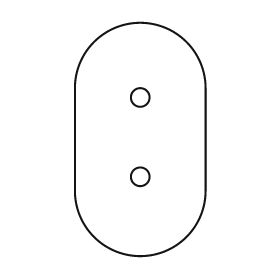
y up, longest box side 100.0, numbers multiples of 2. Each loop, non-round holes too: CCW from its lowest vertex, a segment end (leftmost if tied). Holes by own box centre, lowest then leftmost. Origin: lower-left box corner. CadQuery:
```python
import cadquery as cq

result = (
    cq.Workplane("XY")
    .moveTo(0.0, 28.0)
    .threePointArc((28.0, 0.0), (56.0, 28.0))
    .lineTo(56.0, 72.0)
    .threePointArc((28.0, 100.0), (0.0, 72.0))
    .close()
    .moveTo(28.0, 34.0)
    .circle(4.0)
    .moveTo(28.0, 68.0)
    .circle(4.0)
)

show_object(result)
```